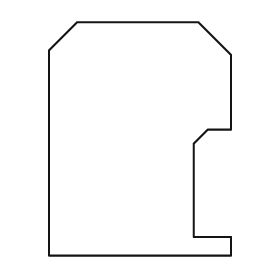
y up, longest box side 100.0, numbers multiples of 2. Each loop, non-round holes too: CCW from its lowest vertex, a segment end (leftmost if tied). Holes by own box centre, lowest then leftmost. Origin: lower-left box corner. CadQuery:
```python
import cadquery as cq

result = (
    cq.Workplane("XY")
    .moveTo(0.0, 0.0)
    .lineTo(78.0, 0.0)
    .lineTo(78.0, 8.0)
    .lineTo(62.0, 8.0)
    .lineTo(62.0, 48.0)
    .lineTo(68.0, 54.0)
    .lineTo(78.0, 54.0)
    .lineTo(78.0, 86.0)
    .lineTo(64.0, 100.0)
    .lineTo(12.0, 100.0)
    .lineTo(0.0, 88.0)
    .close()
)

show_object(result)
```